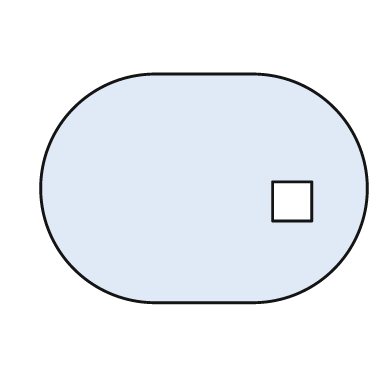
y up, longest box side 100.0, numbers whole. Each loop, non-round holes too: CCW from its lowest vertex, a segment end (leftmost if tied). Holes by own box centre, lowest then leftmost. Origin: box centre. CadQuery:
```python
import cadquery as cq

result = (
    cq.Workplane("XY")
    .moveTo(-15.0, -35.0)
    .lineTo(15.0, -35.0)
    .threePointArc((50.0, 0.0), (15.0, 35.0))
    .lineTo(-15.0, 35.0)
    .threePointArc((-50.0, 0.0), (-15.0, -35.0))
    .close()
    .moveTo(21.0, -10.0)
    .lineTo(33.0, -10.0)
    .lineTo(33.0, 2.0)
    .lineTo(21.0, 2.0)
    .close()
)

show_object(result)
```